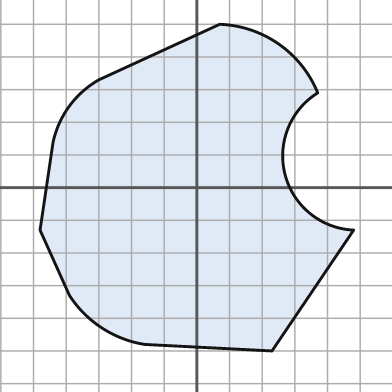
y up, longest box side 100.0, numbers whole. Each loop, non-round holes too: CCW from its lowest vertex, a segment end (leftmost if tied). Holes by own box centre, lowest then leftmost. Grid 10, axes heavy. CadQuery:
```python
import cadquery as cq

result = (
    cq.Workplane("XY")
    .moveTo(23.0, -50.0)
    .lineTo(48.0, -13.0)
    .threePointArc((27.0, 4.0), (37.0, 29.0))
    .threePointArc((25.0, 44.0), (7.0, 50.0))
    .lineTo(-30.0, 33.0)
    .threePointArc((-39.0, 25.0), (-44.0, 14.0))
    .lineTo(-48.0, -13.0)
    .lineTo(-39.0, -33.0)
    .threePointArc((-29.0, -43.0), (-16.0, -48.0))
    .close()
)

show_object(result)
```